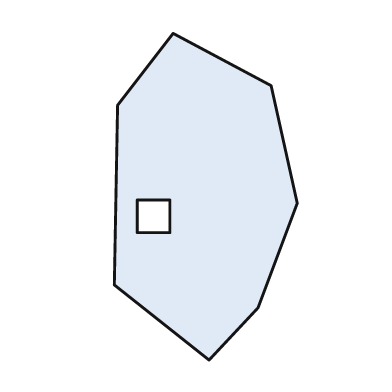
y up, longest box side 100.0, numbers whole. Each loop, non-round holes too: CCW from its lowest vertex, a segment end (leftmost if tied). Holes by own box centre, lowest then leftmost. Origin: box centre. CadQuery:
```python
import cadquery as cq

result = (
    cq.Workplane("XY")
    .moveTo(1.0, -50.0)
    .lineTo(16.0, -34.0)
    .lineTo(28.0, -2.0)
    .lineTo(20.0, 34.0)
    .lineTo(-10.0, 50.0)
    .lineTo(-27.0, 28.0)
    .lineTo(-28.0, -27.0)
    .close()
    .moveTo(-21.0, -11.0)
    .lineTo(-11.0, -11.0)
    .lineTo(-11.0, -1.0)
    .lineTo(-21.0, -1.0)
    .close()
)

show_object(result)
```